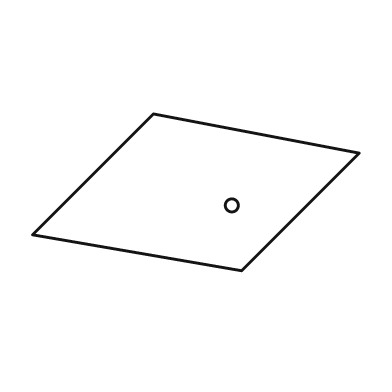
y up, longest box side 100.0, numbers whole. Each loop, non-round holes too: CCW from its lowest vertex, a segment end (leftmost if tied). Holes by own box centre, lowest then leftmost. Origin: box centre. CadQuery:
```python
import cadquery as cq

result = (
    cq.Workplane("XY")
    .moveTo(14.0, -24.0)
    .lineTo(50.0, 12.0)
    .lineTo(-13.0, 24.0)
    .lineTo(-50.0, -13.0)
    .close()
    .moveTo(11.0, -4.0)
    .circle(2.0)
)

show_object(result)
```